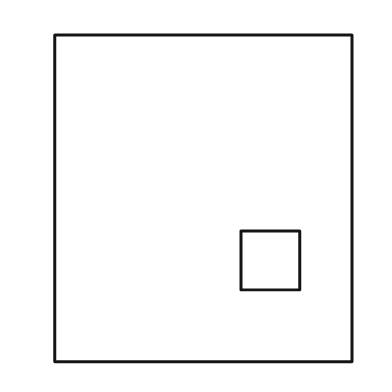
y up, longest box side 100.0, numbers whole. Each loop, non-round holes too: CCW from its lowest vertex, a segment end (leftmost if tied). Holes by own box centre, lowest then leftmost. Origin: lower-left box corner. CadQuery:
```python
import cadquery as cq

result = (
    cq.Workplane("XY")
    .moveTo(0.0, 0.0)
    .lineTo(91.0, 0.0)
    .lineTo(91.0, 100.0)
    .lineTo(0.0, 100.0)
    .close()
    .moveTo(57.0, 22.0)
    .lineTo(75.0, 22.0)
    .lineTo(75.0, 40.0)
    .lineTo(57.0, 40.0)
    .close()
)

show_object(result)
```